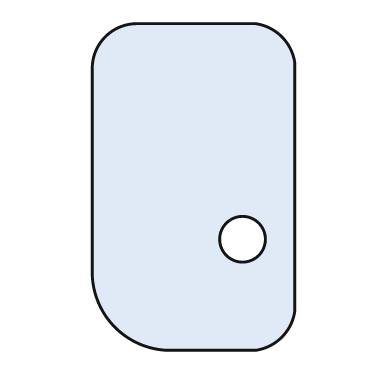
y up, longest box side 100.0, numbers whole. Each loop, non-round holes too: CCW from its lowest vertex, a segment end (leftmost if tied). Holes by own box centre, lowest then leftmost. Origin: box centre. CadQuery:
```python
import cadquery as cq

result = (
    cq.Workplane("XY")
    .moveTo(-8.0, -50.0)
    .lineTo(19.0, -50.0)
    .threePointArc((27.0, -46.0), (31.0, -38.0))
    .lineTo(31.0, 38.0)
    .threePointArc((27.0, 46.0), (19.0, 50.0))
    .lineTo(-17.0, 50.0)
    .threePointArc((-27.0, 46.0), (-31.0, 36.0))
    .lineTo(-31.0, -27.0)
    .threePointArc((-24.0, -43.0), (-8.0, -50.0))
    .close()
    .moveTo(15.0, -16.0)
    .circle(7.0)
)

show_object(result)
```